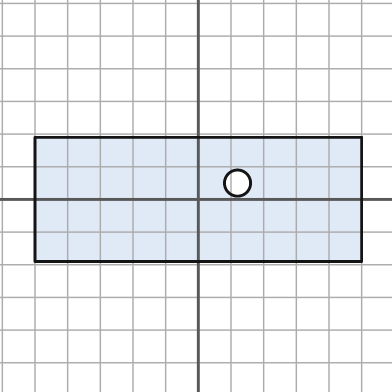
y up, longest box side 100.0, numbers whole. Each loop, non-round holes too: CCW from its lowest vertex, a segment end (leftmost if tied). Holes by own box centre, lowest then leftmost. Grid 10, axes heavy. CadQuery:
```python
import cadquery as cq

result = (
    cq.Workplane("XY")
    .moveTo(-50.0, -19.0)
    .lineTo(50.0, -19.0)
    .lineTo(50.0, 19.0)
    .lineTo(-50.0, 19.0)
    .close()
    .moveTo(12.0, 5.0)
    .circle(4.0)
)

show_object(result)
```